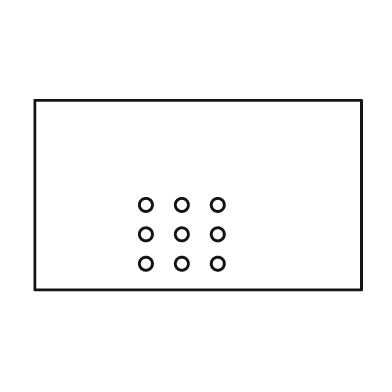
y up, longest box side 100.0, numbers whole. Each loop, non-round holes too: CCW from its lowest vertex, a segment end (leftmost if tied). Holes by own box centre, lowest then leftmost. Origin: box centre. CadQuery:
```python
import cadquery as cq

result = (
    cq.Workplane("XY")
    .moveTo(-50.0, -29.0)
    .lineTo(50.0, -29.0)
    .lineTo(50.0, 29.0)
    .lineTo(-50.0, 29.0)
    .close()
    .moveTo(-16.0, -21.0)
    .circle(2.0)
    .moveTo(-5.0, -21.0)
    .circle(2.0)
    .moveTo(6.0, -21.0)
    .circle(2.0)
    .moveTo(-16.0, -12.0)
    .circle(2.0)
    .moveTo(-5.0, -12.0)
    .circle(2.0)
    .moveTo(6.0, -12.0)
    .circle(2.0)
    .moveTo(-16.0, -3.0)
    .circle(2.0)
    .moveTo(-5.0, -3.0)
    .circle(2.0)
    .moveTo(6.0, -3.0)
    .circle(2.0)
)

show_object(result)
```